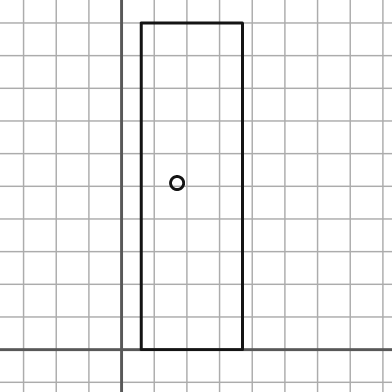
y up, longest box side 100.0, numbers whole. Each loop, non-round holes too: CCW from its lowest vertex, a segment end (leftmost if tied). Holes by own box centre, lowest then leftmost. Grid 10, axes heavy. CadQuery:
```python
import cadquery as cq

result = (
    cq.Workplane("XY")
    .moveTo(6.0, 0.0)
    .lineTo(37.0, 0.0)
    .lineTo(37.0, 100.0)
    .lineTo(6.0, 100.0)
    .close()
    .moveTo(17.0, 51.0)
    .circle(2.0)
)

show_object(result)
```